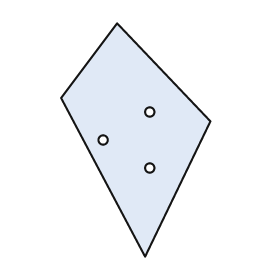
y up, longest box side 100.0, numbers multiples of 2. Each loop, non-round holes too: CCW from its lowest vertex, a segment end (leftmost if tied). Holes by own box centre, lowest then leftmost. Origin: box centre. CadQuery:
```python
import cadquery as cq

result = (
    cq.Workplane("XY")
    .moveTo(4.0, -50.0)
    .lineTo(32.0, 8.0)
    .lineTo(-8.0, 50.0)
    .lineTo(-32.0, 18.0)
    .close()
    .moveTo(6.0, -12.0)
    .circle(2.0)
    .moveTo(-14.0, 0.0)
    .circle(2.0)
    .moveTo(6.0, 12.0)
    .circle(2.0)
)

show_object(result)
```